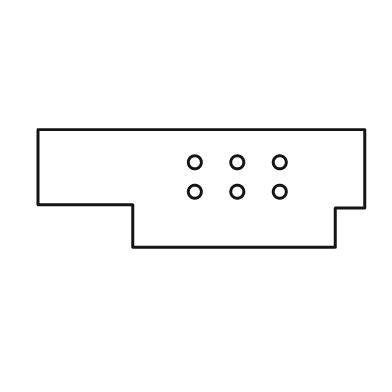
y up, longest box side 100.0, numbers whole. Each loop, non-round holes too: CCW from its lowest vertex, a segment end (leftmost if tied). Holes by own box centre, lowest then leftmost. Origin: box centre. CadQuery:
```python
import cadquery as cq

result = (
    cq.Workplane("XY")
    .moveTo(-21.0, -18.0)
    .lineTo(41.0, -18.0)
    .lineTo(41.0, -6.0)
    .lineTo(50.0, -6.0)
    .lineTo(50.0, 18.0)
    .lineTo(-50.0, 18.0)
    .lineTo(-50.0, -5.0)
    .lineTo(-21.0, -5.0)
    .close()
    .moveTo(-2.0, -1.0)
    .circle(2.0)
    .moveTo(11.0, -1.0)
    .circle(2.0)
    .moveTo(24.0, -1.0)
    .circle(2.0)
    .moveTo(-2.0, 8.0)
    .circle(2.0)
    .moveTo(11.0, 8.0)
    .circle(2.0)
    .moveTo(24.0, 8.0)
    .circle(2.0)
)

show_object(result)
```